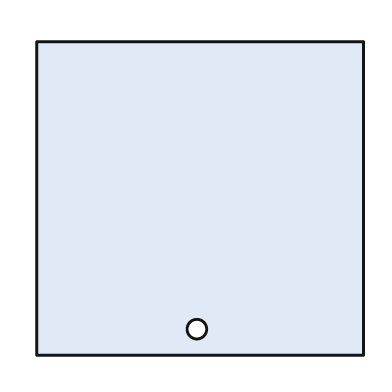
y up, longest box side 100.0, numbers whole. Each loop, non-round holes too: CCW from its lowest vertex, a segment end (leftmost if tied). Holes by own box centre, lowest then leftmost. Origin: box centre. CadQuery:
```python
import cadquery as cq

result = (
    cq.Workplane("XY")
    .moveTo(-50.0, -48.0)
    .lineTo(50.0, -48.0)
    .lineTo(50.0, 48.0)
    .lineTo(-50.0, 48.0)
    .close()
    .moveTo(-1.0, -40.0)
    .circle(3.0)
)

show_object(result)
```